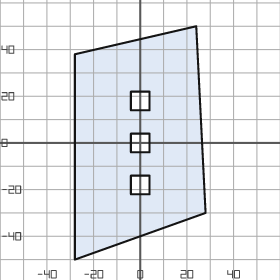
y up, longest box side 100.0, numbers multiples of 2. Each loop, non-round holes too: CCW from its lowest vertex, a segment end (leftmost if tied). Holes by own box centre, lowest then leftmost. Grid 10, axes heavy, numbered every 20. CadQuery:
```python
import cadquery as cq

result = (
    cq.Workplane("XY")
    .moveTo(-28.0, -50.0)
    .lineTo(28.0, -30.0)
    .lineTo(24.0, 50.0)
    .lineTo(-28.0, 38.0)
    .close()
    .moveTo(-4.0, -22.0)
    .lineTo(4.0, -22.0)
    .lineTo(4.0, -14.0)
    .lineTo(-4.0, -14.0)
    .close()
    .moveTo(-4.0, -4.0)
    .lineTo(4.0, -4.0)
    .lineTo(4.0, 4.0)
    .lineTo(-4.0, 4.0)
    .close()
    .moveTo(-4.0, 14.0)
    .lineTo(4.0, 14.0)
    .lineTo(4.0, 22.0)
    .lineTo(-4.0, 22.0)
    .close()
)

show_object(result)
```